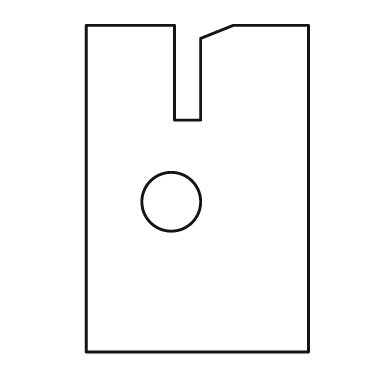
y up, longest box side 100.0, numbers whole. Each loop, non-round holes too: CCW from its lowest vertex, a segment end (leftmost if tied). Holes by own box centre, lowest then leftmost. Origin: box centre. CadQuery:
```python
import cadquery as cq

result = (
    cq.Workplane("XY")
    .moveTo(-34.0, -50.0)
    .lineTo(34.0, -50.0)
    .lineTo(34.0, 50.0)
    .lineTo(11.0, 50.0)
    .lineTo(1.0, 46.0)
    .lineTo(1.0, 21.0)
    .lineTo(-7.0, 21.0)
    .lineTo(-7.0, 50.0)
    .lineTo(-34.0, 50.0)
    .close()
    .moveTo(-8.0, -4.0)
    .circle(9.0)
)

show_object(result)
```